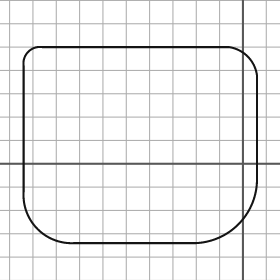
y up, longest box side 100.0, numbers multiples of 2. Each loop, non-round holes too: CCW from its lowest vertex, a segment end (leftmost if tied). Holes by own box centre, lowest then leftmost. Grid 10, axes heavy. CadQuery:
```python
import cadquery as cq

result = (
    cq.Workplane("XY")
    .moveTo(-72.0, -34.0)
    .lineTo(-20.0, -34.0)
    .threePointArc((-2.0, -26.0), (6.0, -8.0))
    .lineTo(6.0, 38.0)
    .threePointArc((2.0, 46.0), (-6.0, 50.0))
    .lineTo(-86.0, 50.0)
    .threePointArc((-92.0, 48.0), (-94.0, 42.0))
    .lineTo(-94.0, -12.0)
    .threePointArc((-88.0, -28.0), (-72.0, -34.0))
    .close()
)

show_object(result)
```